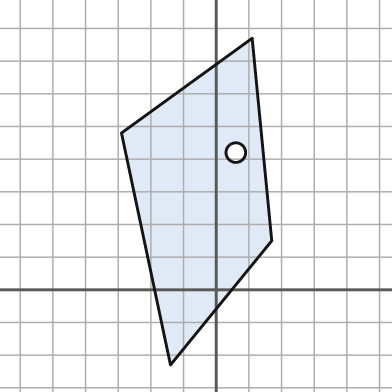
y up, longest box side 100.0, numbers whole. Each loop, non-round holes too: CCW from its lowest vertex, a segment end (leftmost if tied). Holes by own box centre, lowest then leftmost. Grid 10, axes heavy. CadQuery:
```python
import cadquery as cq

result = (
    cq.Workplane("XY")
    .moveTo(-14.0, -23.0)
    .lineTo(17.0, 15.0)
    .lineTo(11.0, 77.0)
    .lineTo(-29.0, 48.0)
    .close()
    .moveTo(6.0, 42.0)
    .circle(3.0)
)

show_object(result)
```